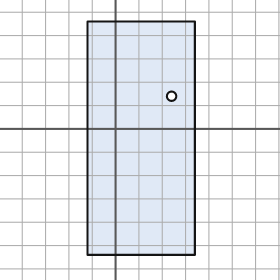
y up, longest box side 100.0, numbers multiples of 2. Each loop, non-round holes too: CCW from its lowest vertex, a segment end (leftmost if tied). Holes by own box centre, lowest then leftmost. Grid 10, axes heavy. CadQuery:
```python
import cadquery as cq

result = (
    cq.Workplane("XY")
    .moveTo(-12.0, -54.0)
    .lineTo(34.0, -54.0)
    .lineTo(34.0, 46.0)
    .lineTo(-12.0, 46.0)
    .close()
    .moveTo(24.0, 14.0)
    .circle(2.0)
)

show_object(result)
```